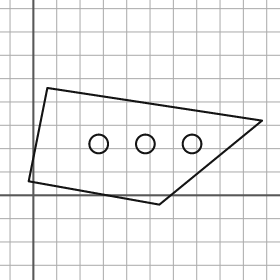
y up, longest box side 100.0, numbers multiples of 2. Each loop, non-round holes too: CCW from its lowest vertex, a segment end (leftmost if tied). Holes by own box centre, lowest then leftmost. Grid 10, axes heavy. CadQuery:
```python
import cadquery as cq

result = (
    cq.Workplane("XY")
    .moveTo(54.0, -4.0)
    .lineTo(98.0, 32.0)
    .lineTo(6.0, 46.0)
    .lineTo(-2.0, 6.0)
    .close()
    .moveTo(28.0, 22.0)
    .circle(4.0)
    .moveTo(48.0, 22.0)
    .circle(4.0)
    .moveTo(68.0, 22.0)
    .circle(4.0)
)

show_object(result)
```